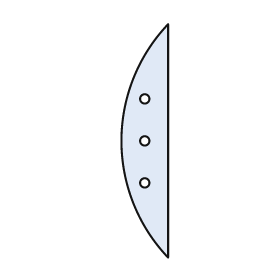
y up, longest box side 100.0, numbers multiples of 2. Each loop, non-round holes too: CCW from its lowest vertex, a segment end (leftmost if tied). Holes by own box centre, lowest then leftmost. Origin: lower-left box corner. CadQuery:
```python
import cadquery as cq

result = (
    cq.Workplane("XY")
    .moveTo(20.0, 0.0)
    .lineTo(20.0, 100.0)
    .threePointArc((0.0, 50.0), (20.0, 0.0))
    .close()
    .moveTo(10.0, 32.0)
    .circle(2.0)
    .moveTo(10.0, 50.0)
    .circle(2.0)
    .moveTo(10.0, 68.0)
    .circle(2.0)
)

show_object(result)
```